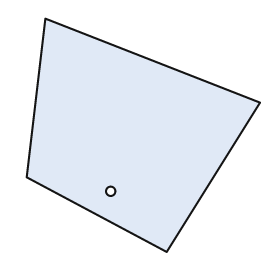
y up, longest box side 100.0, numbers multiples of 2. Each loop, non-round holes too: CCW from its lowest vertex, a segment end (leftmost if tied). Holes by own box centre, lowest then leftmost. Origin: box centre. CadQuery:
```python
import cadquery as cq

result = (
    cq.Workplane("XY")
    .moveTo(10.0, -50.0)
    .lineTo(50.0, 14.0)
    .lineTo(-42.0, 50.0)
    .lineTo(-50.0, -18.0)
    .close()
    .moveTo(-14.0, -24.0)
    .circle(2.0)
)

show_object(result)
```